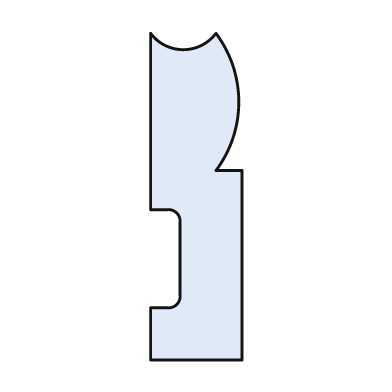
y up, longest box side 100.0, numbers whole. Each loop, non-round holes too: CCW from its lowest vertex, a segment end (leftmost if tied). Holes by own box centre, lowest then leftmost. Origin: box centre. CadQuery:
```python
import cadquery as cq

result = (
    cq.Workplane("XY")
    .moveTo(-14.0, -50.0)
    .lineTo(14.0, -50.0)
    .lineTo(14.0, 8.0)
    .lineTo(6.0, 8.0)
    .threePointArc((13.0, 29.0), (6.0, 50.0))
    .threePointArc((-4.0, 45.0), (-14.0, 50.0))
    .lineTo(-14.0, -4.0)
    .lineTo(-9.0, -4.0)
    .threePointArc((-6.0, -5.0), (-5.0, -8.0))
    .lineTo(-5.0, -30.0)
    .threePointArc((-6.0, -33.0), (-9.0, -34.0))
    .lineTo(-14.0, -34.0)
    .close()
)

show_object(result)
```